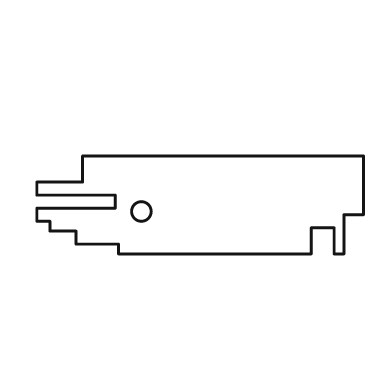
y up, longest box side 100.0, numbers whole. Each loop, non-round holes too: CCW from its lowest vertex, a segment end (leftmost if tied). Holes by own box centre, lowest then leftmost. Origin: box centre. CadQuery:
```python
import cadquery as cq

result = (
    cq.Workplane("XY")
    .moveTo(-25.0, -15.0)
    .lineTo(34.0, -15.0)
    .lineTo(34.0, -7.0)
    .lineTo(41.0, -7.0)
    .lineTo(41.0, -15.0)
    .lineTo(44.0, -15.0)
    .lineTo(44.0, -3.0)
    .lineTo(50.0, -3.0)
    .lineTo(50.0, 15.0)
    .lineTo(-36.0, 15.0)
    .lineTo(-36.0, 7.0)
    .lineTo(-50.0, 7.0)
    .lineTo(-50.0, 3.0)
    .lineTo(-26.0, 3.0)
    .lineTo(-26.0, -1.0)
    .lineTo(-50.0, -1.0)
    .lineTo(-50.0, -5.0)
    .lineTo(-46.0, -5.0)
    .lineTo(-46.0, -8.0)
    .lineTo(-38.0, -8.0)
    .lineTo(-38.0, -12.0)
    .lineTo(-25.0, -12.0)
    .close()
    .moveTo(-18.0, -2.0)
    .circle(3.0)
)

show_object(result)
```